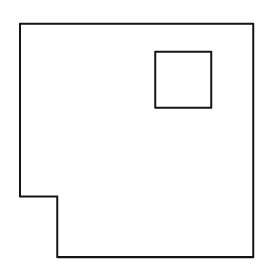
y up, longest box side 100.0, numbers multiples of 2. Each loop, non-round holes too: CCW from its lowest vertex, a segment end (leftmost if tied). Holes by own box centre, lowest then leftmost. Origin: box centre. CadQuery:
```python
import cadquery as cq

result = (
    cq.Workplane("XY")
    .moveTo(-34.0, -50.0)
    .lineTo(50.0, -50.0)
    .lineTo(50.0, 50.0)
    .lineTo(-50.0, 50.0)
    .lineTo(-50.0, -24.0)
    .lineTo(-34.0, -24.0)
    .close()
    .moveTo(8.0, 14.0)
    .lineTo(32.0, 14.0)
    .lineTo(32.0, 38.0)
    .lineTo(8.0, 38.0)
    .close()
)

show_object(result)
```